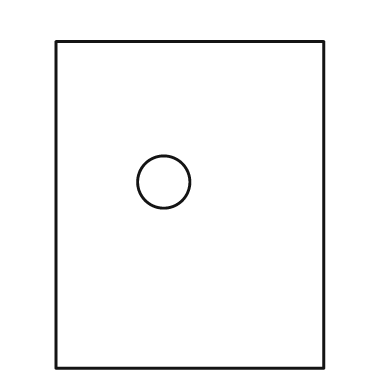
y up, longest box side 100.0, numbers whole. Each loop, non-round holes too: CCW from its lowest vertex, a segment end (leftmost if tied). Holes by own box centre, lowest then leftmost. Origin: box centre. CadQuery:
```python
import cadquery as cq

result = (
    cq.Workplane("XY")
    .moveTo(-41.0, -50.0)
    .lineTo(41.0, -50.0)
    .lineTo(41.0, 50.0)
    .lineTo(-41.0, 50.0)
    .close()
    .moveTo(-8.0, 7.0)
    .circle(8.0)
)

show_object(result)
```